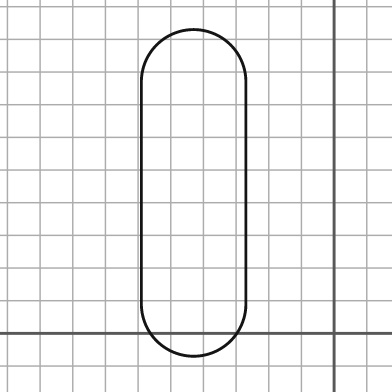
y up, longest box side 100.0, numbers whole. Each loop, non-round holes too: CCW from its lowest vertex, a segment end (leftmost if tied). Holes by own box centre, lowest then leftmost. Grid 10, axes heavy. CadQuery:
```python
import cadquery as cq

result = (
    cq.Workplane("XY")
    .moveTo(-59.0, 9.0)
    .threePointArc((-43.0, -7.0), (-27.0, 9.0))
    .lineTo(-27.0, 77.0)
    .threePointArc((-43.0, 93.0), (-59.0, 77.0))
    .close()
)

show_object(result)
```